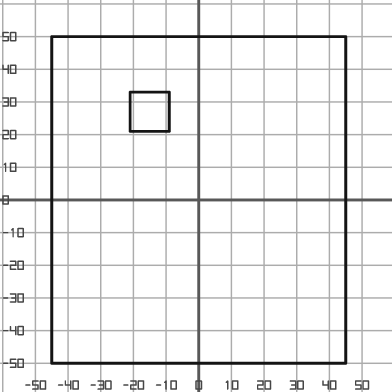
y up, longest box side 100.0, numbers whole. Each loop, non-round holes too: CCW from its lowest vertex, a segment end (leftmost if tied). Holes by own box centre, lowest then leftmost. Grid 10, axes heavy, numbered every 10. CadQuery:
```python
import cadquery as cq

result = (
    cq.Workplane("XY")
    .moveTo(-45.0, -50.0)
    .lineTo(45.0, -50.0)
    .lineTo(45.0, 50.0)
    .lineTo(-45.0, 50.0)
    .close()
    .moveTo(-21.0, 21.0)
    .lineTo(-9.0, 21.0)
    .lineTo(-9.0, 33.0)
    .lineTo(-21.0, 33.0)
    .close()
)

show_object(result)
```